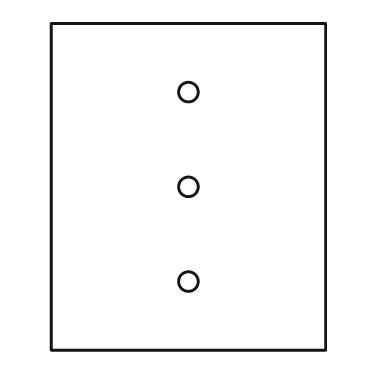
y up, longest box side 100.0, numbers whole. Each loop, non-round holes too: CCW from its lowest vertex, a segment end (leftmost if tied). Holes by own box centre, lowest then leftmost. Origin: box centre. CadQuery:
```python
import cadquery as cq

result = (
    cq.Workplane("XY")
    .moveTo(-42.0, -50.0)
    .lineTo(42.0, -50.0)
    .lineTo(42.0, 50.0)
    .lineTo(-42.0, 50.0)
    .close()
    .moveTo(0.0, -29.0)
    .circle(3.0)
    .moveTo(0.0, 0.0)
    .circle(3.0)
    .moveTo(0.0, 29.0)
    .circle(3.0)
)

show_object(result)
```